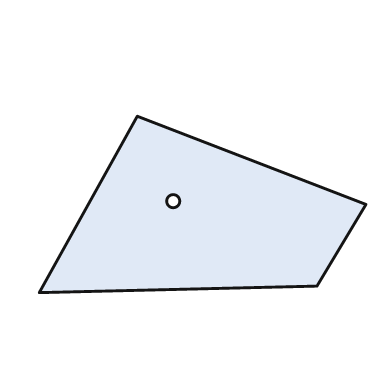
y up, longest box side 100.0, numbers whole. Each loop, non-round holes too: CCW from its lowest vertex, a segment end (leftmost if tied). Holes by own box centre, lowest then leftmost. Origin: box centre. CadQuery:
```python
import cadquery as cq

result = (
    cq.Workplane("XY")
    .moveTo(-50.0, -27.0)
    .lineTo(35.0, -25.0)
    .lineTo(50.0, 0.0)
    .lineTo(-20.0, 27.0)
    .close()
    .moveTo(-9.0, 1.0)
    .circle(2.0)
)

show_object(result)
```